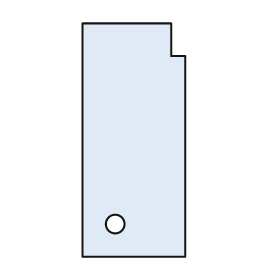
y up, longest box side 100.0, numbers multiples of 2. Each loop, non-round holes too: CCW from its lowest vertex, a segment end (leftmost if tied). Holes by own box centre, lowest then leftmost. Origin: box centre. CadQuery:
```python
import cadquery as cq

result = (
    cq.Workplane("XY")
    .moveTo(-22.0, -50.0)
    .lineTo(22.0, -50.0)
    .lineTo(22.0, 36.0)
    .lineTo(16.0, 36.0)
    .lineTo(16.0, 50.0)
    .lineTo(-22.0, 50.0)
    .close()
    .moveTo(-8.0, -36.0)
    .circle(4.0)
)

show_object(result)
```